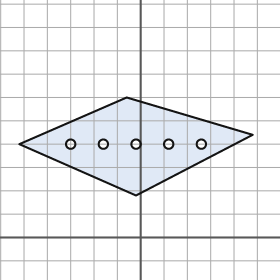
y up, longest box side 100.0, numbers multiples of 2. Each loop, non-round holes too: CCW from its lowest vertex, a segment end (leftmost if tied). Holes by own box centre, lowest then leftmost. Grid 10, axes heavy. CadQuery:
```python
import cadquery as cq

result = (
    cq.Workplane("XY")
    .moveTo(-2.0, 18.0)
    .lineTo(48.0, 44.0)
    .lineTo(-6.0, 60.0)
    .lineTo(-52.0, 40.0)
    .close()
    .moveTo(-30.0, 40.0)
    .circle(2.0)
    .moveTo(-16.0, 40.0)
    .circle(2.0)
    .moveTo(-2.0, 40.0)
    .circle(2.0)
    .moveTo(12.0, 40.0)
    .circle(2.0)
    .moveTo(26.0, 40.0)
    .circle(2.0)
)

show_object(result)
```